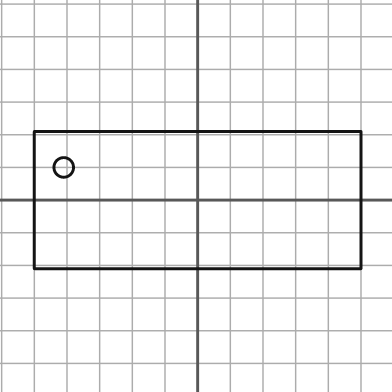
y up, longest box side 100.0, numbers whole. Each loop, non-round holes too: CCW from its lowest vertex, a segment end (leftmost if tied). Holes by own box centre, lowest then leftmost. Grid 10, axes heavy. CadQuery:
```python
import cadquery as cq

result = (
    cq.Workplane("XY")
    .moveTo(-50.0, -21.0)
    .lineTo(50.0, -21.0)
    .lineTo(50.0, 21.0)
    .lineTo(-50.0, 21.0)
    .close()
    .moveTo(-41.0, 10.0)
    .circle(3.0)
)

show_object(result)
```